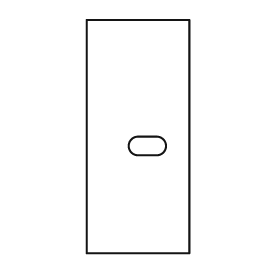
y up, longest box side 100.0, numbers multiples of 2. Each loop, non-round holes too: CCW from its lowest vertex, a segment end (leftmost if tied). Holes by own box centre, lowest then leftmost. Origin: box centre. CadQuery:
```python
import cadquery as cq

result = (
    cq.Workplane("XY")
    .moveTo(-22.0, -50.0)
    .lineTo(22.0, -50.0)
    .lineTo(22.0, 50.0)
    .lineTo(-22.0, 50.0)
    .close()
    .moveTo(0.0, -8.0)
    .lineTo(8.0, -8.0)
    .threePointArc((12.0, -4.0), (8.0, 0.0))
    .lineTo(0.0, 0.0)
    .threePointArc((-4.0, -4.0), (0.0, -8.0))
    .close()
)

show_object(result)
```